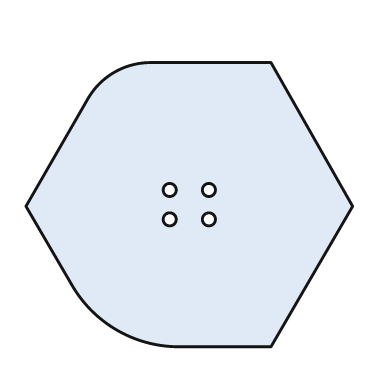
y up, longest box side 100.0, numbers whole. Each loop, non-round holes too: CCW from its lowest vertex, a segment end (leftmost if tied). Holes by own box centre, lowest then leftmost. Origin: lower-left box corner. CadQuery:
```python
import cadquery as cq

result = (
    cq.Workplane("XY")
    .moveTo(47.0, 0.0)
    .lineTo(75.0, 0.0)
    .lineTo(100.0, 43.0)
    .lineTo(75.0, 87.0)
    .lineTo(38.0, 87.0)
    .threePointArc((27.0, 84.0), (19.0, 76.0))
    .lineTo(0.0, 43.0)
    .lineTo(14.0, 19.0)
    .threePointArc((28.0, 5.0), (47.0, 0.0))
    .close()
    .moveTo(44.0, 39.0)
    .circle(2.0)
    .moveTo(56.0, 39.0)
    .circle(2.0)
    .moveTo(44.0, 48.0)
    .circle(2.0)
    .moveTo(56.0, 48.0)
    .circle(2.0)
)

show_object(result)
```